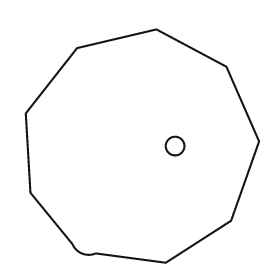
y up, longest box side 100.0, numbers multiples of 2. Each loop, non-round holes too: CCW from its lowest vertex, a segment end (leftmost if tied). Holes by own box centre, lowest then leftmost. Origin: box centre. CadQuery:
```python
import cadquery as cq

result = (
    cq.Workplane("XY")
    .moveTo(10.0, -50.0)
    .lineTo(38.0, -32.0)
    .lineTo(50.0, 2.0)
    .lineTo(36.0, 34.0)
    .lineTo(6.0, 50.0)
    .lineTo(-28.0, 42.0)
    .lineTo(-50.0, 14.0)
    .lineTo(-48.0, -20.0)
    .lineTo(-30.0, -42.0)
    .threePointArc((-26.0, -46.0), (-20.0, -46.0))
    .close()
    .moveTo(14.0, 0.0)
    .circle(4.0)
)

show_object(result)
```